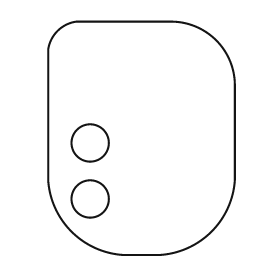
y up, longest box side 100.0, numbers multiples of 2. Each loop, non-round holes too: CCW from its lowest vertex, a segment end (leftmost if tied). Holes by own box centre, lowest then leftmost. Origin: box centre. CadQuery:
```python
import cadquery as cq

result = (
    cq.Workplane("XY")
    .moveTo(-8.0, -50.0)
    .lineTo(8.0, -50.0)
    .threePointArc((30.0, -40.0), (40.0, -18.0))
    .lineTo(40.0, 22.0)
    .threePointArc((32.0, 42.0), (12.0, 50.0))
    .lineTo(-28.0, 50.0)
    .threePointArc((-36.0, 46.0), (-40.0, 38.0))
    .lineTo(-40.0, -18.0)
    .threePointArc((-30.0, -40.0), (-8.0, -50.0))
    .close()
    .moveTo(-22.0, -26.0)
    .circle(8.0)
    .moveTo(-22.0, -2.0)
    .circle(8.0)
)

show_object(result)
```